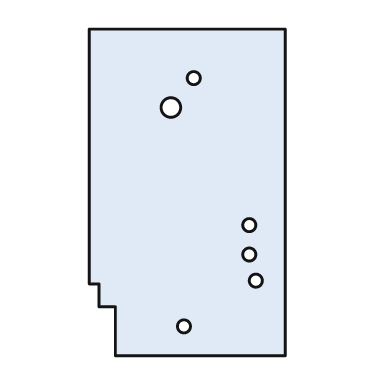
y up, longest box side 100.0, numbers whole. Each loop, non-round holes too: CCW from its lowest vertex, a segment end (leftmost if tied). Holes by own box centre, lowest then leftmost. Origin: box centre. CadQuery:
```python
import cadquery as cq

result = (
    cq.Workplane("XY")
    .moveTo(-22.0, -50.0)
    .lineTo(30.0, -50.0)
    .lineTo(30.0, 50.0)
    .lineTo(-30.0, 50.0)
    .lineTo(-30.0, -28.0)
    .lineTo(-27.0, -28.0)
    .lineTo(-27.0, -35.0)
    .lineTo(-22.0, -35.0)
    .close()
    .moveTo(-1.0, -41.0)
    .circle(2.0)
    .moveTo(21.0, -27.0)
    .circle(2.0)
    .moveTo(19.0, -19.0)
    .circle(2.0)
    .moveTo(19.0, -10.0)
    .circle(2.0)
    .moveTo(-5.0, 26.0)
    .circle(3.0)
    .moveTo(2.0, 35.0)
    .circle(2.0)
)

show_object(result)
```